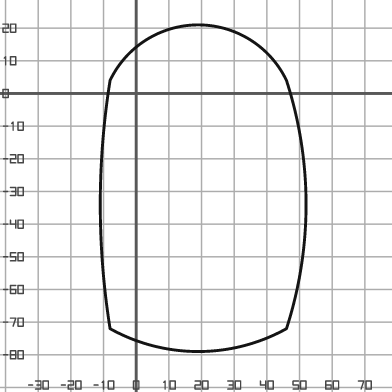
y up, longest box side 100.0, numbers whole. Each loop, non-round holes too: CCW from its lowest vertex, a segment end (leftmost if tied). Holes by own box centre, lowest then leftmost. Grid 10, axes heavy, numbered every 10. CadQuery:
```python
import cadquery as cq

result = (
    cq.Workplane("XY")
    .moveTo(-8.0, -72.0)
    .threePointArc((19.0, -79.0), (46.0, -72.0))
    .threePointArc((52.0, -34.0), (46.0, 4.0))
    .threePointArc((19.0, 21.0), (-8.0, 4.0))
    .threePointArc((-11.0, -34.0), (-8.0, -72.0))
    .close()
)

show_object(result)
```